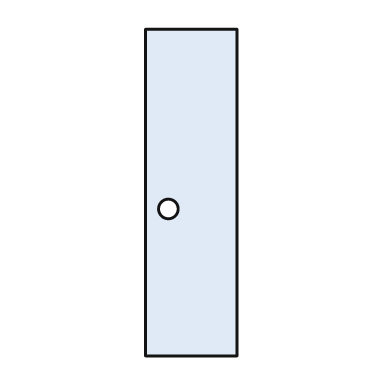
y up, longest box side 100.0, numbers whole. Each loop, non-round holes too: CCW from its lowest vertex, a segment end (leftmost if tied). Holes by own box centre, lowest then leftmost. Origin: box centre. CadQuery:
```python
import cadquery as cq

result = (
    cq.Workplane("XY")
    .moveTo(-14.0, -50.0)
    .lineTo(14.0, -50.0)
    .lineTo(14.0, 50.0)
    .lineTo(-14.0, 50.0)
    .close()
    .moveTo(-7.0, -5.0)
    .circle(3.0)
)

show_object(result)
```